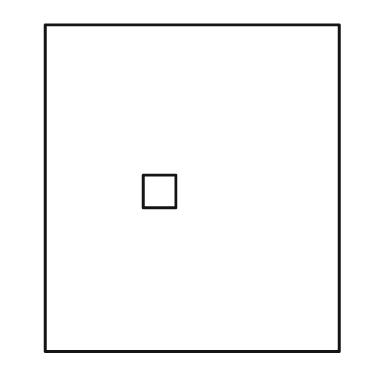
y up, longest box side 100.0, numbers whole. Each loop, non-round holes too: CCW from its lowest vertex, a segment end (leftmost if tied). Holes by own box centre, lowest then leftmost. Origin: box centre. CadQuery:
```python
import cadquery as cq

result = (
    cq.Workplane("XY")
    .moveTo(-45.0, -50.0)
    .lineTo(45.0, -50.0)
    .lineTo(45.0, 50.0)
    .lineTo(-45.0, 50.0)
    .close()
    .moveTo(-15.0, -6.0)
    .lineTo(-5.0, -6.0)
    .lineTo(-5.0, 4.0)
    .lineTo(-15.0, 4.0)
    .close()
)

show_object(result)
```